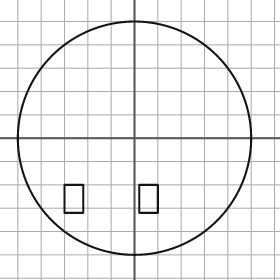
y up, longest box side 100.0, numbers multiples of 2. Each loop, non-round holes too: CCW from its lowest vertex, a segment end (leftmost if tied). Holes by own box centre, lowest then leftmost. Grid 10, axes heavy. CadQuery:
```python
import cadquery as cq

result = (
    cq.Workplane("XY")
    .moveTo(0.0, 0.0)
    .circle(50.0)
    .moveTo(-30.0, -32.0)
    .lineTo(-22.0, -32.0)
    .lineTo(-22.0, -20.0)
    .lineTo(-30.0, -20.0)
    .close()
    .moveTo(2.0, -32.0)
    .lineTo(10.0, -32.0)
    .lineTo(10.0, -20.0)
    .lineTo(2.0, -20.0)
    .close()
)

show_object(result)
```